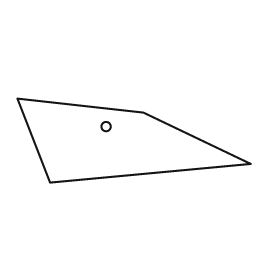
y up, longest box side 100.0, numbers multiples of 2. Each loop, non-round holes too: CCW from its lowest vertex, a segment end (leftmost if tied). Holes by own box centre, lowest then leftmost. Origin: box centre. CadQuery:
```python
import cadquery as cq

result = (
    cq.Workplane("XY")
    .moveTo(-36.0, -18.0)
    .lineTo(50.0, -10.0)
    .lineTo(4.0, 12.0)
    .lineTo(-50.0, 18.0)
    .close()
    .moveTo(-12.0, 6.0)
    .circle(2.0)
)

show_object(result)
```